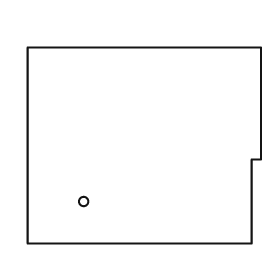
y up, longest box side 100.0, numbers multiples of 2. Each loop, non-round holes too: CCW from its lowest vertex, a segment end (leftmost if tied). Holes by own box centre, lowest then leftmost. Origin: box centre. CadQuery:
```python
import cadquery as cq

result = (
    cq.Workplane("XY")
    .moveTo(-50.0, -42.0)
    .lineTo(46.0, -42.0)
    .lineTo(46.0, -6.0)
    .lineTo(50.0, -6.0)
    .lineTo(50.0, 42.0)
    .lineTo(-50.0, 42.0)
    .close()
    .moveTo(-26.0, -24.0)
    .circle(2.0)
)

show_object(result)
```